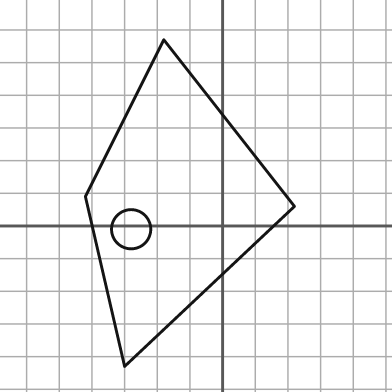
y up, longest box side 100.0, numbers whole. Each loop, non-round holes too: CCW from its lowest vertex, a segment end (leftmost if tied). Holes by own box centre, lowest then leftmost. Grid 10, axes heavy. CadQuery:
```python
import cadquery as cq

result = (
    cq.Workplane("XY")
    .moveTo(-30.0, -43.0)
    .lineTo(22.0, 6.0)
    .lineTo(-18.0, 57.0)
    .lineTo(-42.0, 9.0)
    .close()
    .moveTo(-28.0, -1.0)
    .circle(6.0)
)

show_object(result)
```